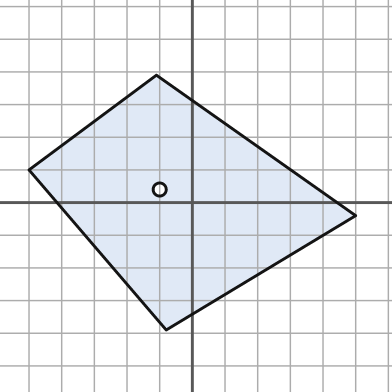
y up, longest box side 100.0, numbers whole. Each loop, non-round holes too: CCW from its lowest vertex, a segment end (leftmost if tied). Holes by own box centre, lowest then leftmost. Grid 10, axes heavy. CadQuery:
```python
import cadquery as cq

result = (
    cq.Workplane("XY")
    .moveTo(-8.0, -39.0)
    .lineTo(50.0, -4.0)
    .lineTo(-11.0, 39.0)
    .lineTo(-50.0, 10.0)
    .close()
    .moveTo(-10.0, 4.0)
    .circle(2.0)
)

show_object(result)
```